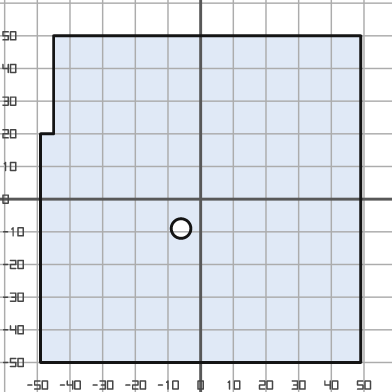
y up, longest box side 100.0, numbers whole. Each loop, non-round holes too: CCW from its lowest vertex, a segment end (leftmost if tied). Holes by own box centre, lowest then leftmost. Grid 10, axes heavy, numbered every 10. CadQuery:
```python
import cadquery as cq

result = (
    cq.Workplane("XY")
    .moveTo(-49.0, -50.0)
    .lineTo(49.0, -50.0)
    .lineTo(49.0, 50.0)
    .lineTo(-45.0, 50.0)
    .lineTo(-45.0, 20.0)
    .lineTo(-49.0, 20.0)
    .close()
    .moveTo(-6.0, -9.0)
    .circle(3.0)
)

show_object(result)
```